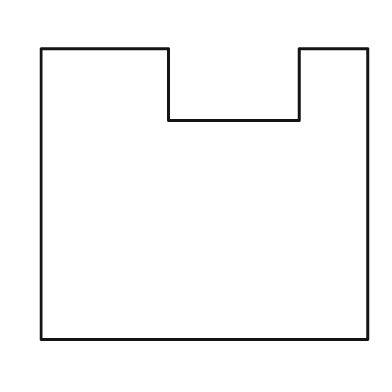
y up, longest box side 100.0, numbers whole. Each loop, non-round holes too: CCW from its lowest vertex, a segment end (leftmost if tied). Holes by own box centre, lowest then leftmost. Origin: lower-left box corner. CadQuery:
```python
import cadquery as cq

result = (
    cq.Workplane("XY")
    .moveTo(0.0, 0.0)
    .lineTo(100.0, 0.0)
    .lineTo(100.0, 89.0)
    .lineTo(79.0, 89.0)
    .lineTo(79.0, 67.0)
    .lineTo(39.0, 67.0)
    .lineTo(39.0, 89.0)
    .lineTo(0.0, 89.0)
    .close()
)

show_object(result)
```